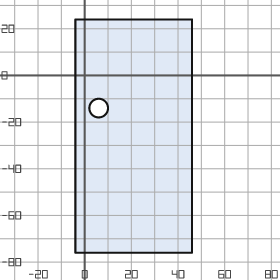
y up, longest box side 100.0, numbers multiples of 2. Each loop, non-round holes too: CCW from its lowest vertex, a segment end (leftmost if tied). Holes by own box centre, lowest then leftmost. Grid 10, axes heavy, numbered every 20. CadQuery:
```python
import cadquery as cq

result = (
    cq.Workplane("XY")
    .moveTo(-4.0, -76.0)
    .lineTo(46.0, -76.0)
    .lineTo(46.0, 24.0)
    .lineTo(-4.0, 24.0)
    .close()
    .moveTo(6.0, -14.0)
    .circle(4.0)
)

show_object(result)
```